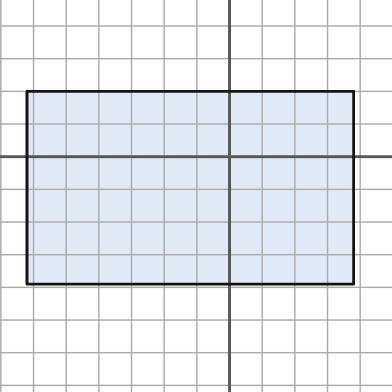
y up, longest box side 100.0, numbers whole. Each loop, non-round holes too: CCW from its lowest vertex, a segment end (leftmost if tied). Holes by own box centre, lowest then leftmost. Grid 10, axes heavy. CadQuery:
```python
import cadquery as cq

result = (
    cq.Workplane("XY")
    .moveTo(-62.0, -39.0)
    .lineTo(38.0, -39.0)
    .lineTo(38.0, 20.0)
    .lineTo(-62.0, 20.0)
    .close()
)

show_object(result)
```